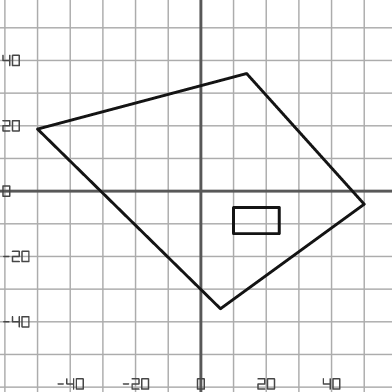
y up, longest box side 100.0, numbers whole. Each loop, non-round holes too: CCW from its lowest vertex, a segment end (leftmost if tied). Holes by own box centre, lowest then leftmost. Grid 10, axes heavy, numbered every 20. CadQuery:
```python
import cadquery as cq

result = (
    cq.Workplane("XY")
    .moveTo(6.0, -36.0)
    .lineTo(50.0, -4.0)
    .lineTo(14.0, 36.0)
    .lineTo(-50.0, 19.0)
    .close()
    .moveTo(10.0, -13.0)
    .lineTo(24.0, -13.0)
    .lineTo(24.0, -5.0)
    .lineTo(10.0, -5.0)
    .close()
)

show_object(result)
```